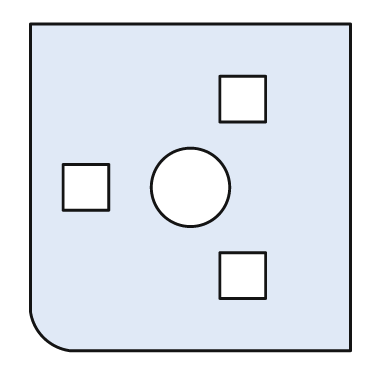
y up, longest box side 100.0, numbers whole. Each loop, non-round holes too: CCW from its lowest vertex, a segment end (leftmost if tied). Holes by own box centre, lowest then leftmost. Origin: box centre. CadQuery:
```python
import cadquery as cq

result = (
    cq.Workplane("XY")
    .moveTo(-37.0, -50.0)
    .lineTo(49.0, -50.0)
    .lineTo(49.0, 50.0)
    .lineTo(-49.0, 50.0)
    .lineTo(-49.0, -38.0)
    .threePointArc((-45.0, -46.0), (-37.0, -50.0))
    .close()
    .moveTo(9.0, -34.0)
    .lineTo(23.0, -34.0)
    .lineTo(23.0, -20.0)
    .lineTo(9.0, -20.0)
    .close()
    .moveTo(-39.0, -7.0)
    .lineTo(-25.0, -7.0)
    .lineTo(-25.0, 7.0)
    .lineTo(-39.0, 7.0)
    .close()
    .moveTo(0.0, 0.0)
    .circle(12.0)
    .moveTo(9.0, 20.0)
    .lineTo(23.0, 20.0)
    .lineTo(23.0, 34.0)
    .lineTo(9.0, 34.0)
    .close()
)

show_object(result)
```